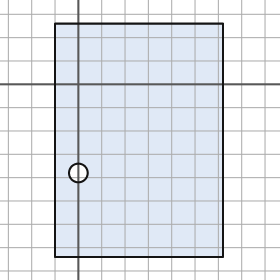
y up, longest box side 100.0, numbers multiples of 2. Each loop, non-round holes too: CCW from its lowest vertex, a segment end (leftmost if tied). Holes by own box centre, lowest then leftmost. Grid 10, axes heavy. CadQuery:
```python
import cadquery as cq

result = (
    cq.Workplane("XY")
    .moveTo(-10.0, -74.0)
    .lineTo(62.0, -74.0)
    .lineTo(62.0, 26.0)
    .lineTo(-10.0, 26.0)
    .close()
    .moveTo(0.0, -38.0)
    .circle(4.0)
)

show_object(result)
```